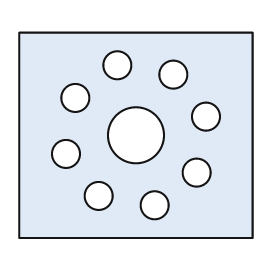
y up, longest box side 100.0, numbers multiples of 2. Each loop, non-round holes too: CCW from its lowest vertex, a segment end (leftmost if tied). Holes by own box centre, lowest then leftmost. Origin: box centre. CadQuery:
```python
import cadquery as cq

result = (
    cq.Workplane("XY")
    .moveTo(-50.0, -44.0)
    .lineTo(50.0, -44.0)
    .lineTo(50.0, 44.0)
    .lineTo(-50.0, 44.0)
    .close()
    .moveTo(8.0, -30.0)
    .circle(6.0)
    .moveTo(-16.0, -26.0)
    .circle(6.0)
    .moveTo(26.0, -16.0)
    .circle(6.0)
    .moveTo(-30.0, -8.0)
    .circle(6.0)
    .moveTo(0.0, 0.0)
    .circle(12.0)
    .moveTo(30.0, 8.0)
    .circle(6.0)
    .moveTo(-26.0, 16.0)
    .circle(6.0)
    .moveTo(16.0, 26.0)
    .circle(6.0)
    .moveTo(-8.0, 30.0)
    .circle(6.0)
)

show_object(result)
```